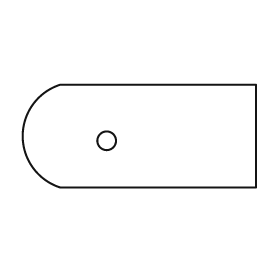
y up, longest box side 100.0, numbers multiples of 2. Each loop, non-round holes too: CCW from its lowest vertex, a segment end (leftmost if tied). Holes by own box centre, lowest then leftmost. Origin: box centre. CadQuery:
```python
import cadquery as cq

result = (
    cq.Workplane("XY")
    .moveTo(-34.0, -22.0)
    .lineTo(50.0, -22.0)
    .lineTo(50.0, 22.0)
    .lineTo(-34.0, 22.0)
    .threePointArc((-50.0, 0.0), (-34.0, -22.0))
    .close()
    .moveTo(-14.0, -2.0)
    .circle(4.0)
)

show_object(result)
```